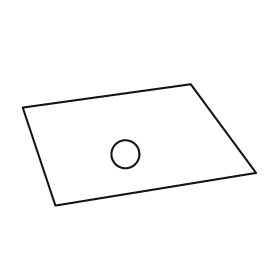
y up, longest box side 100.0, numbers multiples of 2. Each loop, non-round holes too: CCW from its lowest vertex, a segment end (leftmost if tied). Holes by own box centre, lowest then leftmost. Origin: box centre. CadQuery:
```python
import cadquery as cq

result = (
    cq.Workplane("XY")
    .moveTo(-36.0, -26.0)
    .lineTo(50.0, -12.0)
    .lineTo(22.0, 26.0)
    .lineTo(-50.0, 16.0)
    .close()
    .moveTo(-6.0, -4.0)
    .circle(6.0)
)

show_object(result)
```